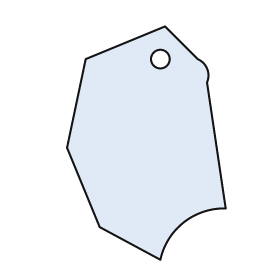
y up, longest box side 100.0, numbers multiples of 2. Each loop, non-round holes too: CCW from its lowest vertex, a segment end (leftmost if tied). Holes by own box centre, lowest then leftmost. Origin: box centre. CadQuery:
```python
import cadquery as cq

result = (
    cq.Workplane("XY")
    .moveTo(6.0, -50.0)
    .threePointArc((16.0, -34.0), (34.0, -28.0))
    .lineTo(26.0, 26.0)
    .threePointArc((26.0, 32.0), (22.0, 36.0))
    .lineTo(8.0, 50.0)
    .lineTo(-26.0, 36.0)
    .lineTo(-34.0, -2.0)
    .lineTo(-20.0, -36.0)
    .close()
    .moveTo(6.0, 36.0)
    .circle(4.0)
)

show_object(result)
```